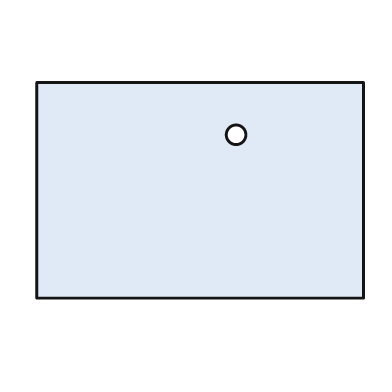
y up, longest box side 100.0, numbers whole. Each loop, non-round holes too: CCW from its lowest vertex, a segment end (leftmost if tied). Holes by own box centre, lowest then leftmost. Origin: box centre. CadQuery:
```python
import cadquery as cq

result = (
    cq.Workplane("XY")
    .moveTo(-50.0, -33.0)
    .lineTo(50.0, -33.0)
    .lineTo(50.0, 33.0)
    .lineTo(-50.0, 33.0)
    .close()
    .moveTo(11.0, 17.0)
    .circle(3.0)
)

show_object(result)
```